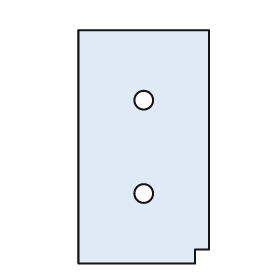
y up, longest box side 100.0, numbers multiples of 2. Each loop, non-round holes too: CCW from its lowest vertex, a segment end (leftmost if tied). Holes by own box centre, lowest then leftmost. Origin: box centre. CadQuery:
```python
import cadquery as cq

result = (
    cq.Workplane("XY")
    .moveTo(-28.0, -50.0)
    .lineTo(22.0, -50.0)
    .lineTo(22.0, -44.0)
    .lineTo(28.0, -44.0)
    .lineTo(28.0, 50.0)
    .lineTo(-28.0, 50.0)
    .close()
    .moveTo(0.0, -20.0)
    .circle(4.0)
    .moveTo(0.0, 20.0)
    .circle(4.0)
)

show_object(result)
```